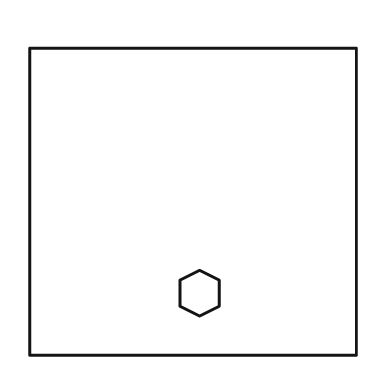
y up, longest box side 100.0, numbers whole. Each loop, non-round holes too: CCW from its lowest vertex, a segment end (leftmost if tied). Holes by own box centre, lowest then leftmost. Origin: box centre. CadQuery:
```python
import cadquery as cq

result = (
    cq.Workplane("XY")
    .moveTo(-50.0, -47.0)
    .lineTo(50.0, -47.0)
    .lineTo(50.0, 47.0)
    .lineTo(-50.0, 47.0)
    .close()
    .moveTo(2.0, -35.0)
    .lineTo(8.0, -32.0)
    .lineTo(8.0, -24.0)
    .lineTo(2.0, -21.0)
    .lineTo(-4.0, -24.0)
    .lineTo(-4.0, -32.0)
    .close()
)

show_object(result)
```